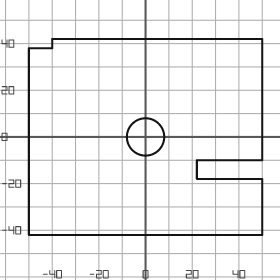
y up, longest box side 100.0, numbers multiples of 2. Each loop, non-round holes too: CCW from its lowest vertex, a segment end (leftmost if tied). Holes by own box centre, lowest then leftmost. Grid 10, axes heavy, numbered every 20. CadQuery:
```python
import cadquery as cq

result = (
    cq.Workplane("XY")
    .moveTo(-50.0, -42.0)
    .lineTo(50.0, -42.0)
    .lineTo(50.0, -18.0)
    .lineTo(22.0, -18.0)
    .lineTo(22.0, -10.0)
    .lineTo(50.0, -10.0)
    .lineTo(50.0, 42.0)
    .lineTo(-40.0, 42.0)
    .lineTo(-40.0, 38.0)
    .lineTo(-50.0, 38.0)
    .close()
    .moveTo(0.0, 0.0)
    .circle(8.0)
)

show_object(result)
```